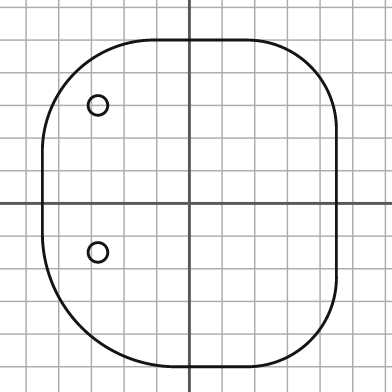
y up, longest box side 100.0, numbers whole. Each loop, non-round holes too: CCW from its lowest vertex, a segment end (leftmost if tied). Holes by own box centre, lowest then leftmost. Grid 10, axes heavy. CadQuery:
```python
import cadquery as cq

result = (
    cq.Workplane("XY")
    .moveTo(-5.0, -50.0)
    .lineTo(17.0, -50.0)
    .threePointArc((37.0, -42.0), (45.0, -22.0))
    .lineTo(45.0, 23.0)
    .threePointArc((37.0, 42.0), (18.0, 50.0))
    .lineTo(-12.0, 50.0)
    .threePointArc((-35.0, 40.0), (-45.0, 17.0))
    .lineTo(-45.0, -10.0)
    .threePointArc((-33.0, -38.0), (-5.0, -50.0))
    .close()
    .moveTo(-28.0, -15.0)
    .circle(3.0)
    .moveTo(-28.0, 30.0)
    .circle(3.0)
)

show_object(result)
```